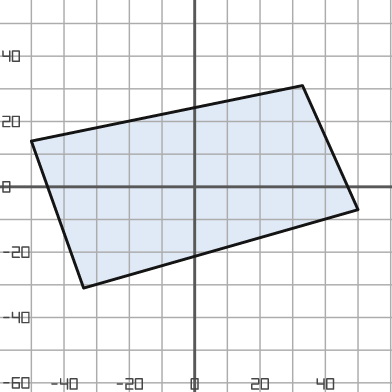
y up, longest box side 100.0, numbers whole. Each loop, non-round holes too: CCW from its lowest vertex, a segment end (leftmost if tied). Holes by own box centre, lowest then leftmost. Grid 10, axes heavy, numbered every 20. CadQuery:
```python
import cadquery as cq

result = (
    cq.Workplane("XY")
    .moveTo(-34.0, -31.0)
    .lineTo(50.0, -7.0)
    .lineTo(33.0, 31.0)
    .lineTo(-50.0, 14.0)
    .close()
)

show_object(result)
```